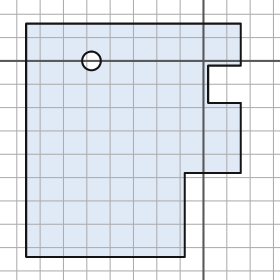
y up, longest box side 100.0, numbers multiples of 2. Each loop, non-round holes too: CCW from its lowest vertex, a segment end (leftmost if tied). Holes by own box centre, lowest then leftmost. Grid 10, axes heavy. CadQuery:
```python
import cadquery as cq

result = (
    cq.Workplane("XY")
    .moveTo(-76.0, -84.0)
    .lineTo(-8.0, -84.0)
    .lineTo(-8.0, -48.0)
    .lineTo(16.0, -48.0)
    .lineTo(16.0, -18.0)
    .lineTo(2.0, -18.0)
    .lineTo(2.0, -2.0)
    .lineTo(16.0, -2.0)
    .lineTo(16.0, 16.0)
    .lineTo(-76.0, 16.0)
    .close()
    .moveTo(-48.0, 0.0)
    .circle(4.0)
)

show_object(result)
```